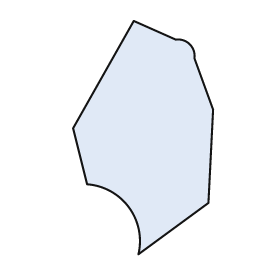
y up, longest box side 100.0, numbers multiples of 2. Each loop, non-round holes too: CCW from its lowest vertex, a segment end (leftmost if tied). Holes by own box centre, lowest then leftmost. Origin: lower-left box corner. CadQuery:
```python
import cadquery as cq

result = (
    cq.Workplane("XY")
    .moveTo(28.0, 0.0)
    .lineTo(58.0, 22.0)
    .lineTo(60.0, 62.0)
    .lineTo(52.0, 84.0)
    .threePointArc((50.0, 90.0), (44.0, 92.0))
    .lineTo(26.0, 100.0)
    .lineTo(0.0, 54.0)
    .lineTo(6.0, 30.0)
    .threePointArc((24.0, 20.0), (28.0, 0.0))
    .close()
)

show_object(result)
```